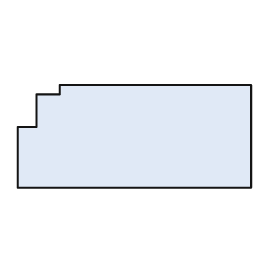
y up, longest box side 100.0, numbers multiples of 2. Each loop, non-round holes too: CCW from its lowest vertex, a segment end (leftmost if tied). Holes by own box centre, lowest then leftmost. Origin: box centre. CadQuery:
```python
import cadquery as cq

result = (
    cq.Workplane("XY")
    .moveTo(-50.0, -22.0)
    .lineTo(50.0, -22.0)
    .lineTo(50.0, 22.0)
    .lineTo(-32.0, 22.0)
    .lineTo(-32.0, 18.0)
    .lineTo(-42.0, 18.0)
    .lineTo(-42.0, 4.0)
    .lineTo(-50.0, 4.0)
    .close()
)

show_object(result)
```